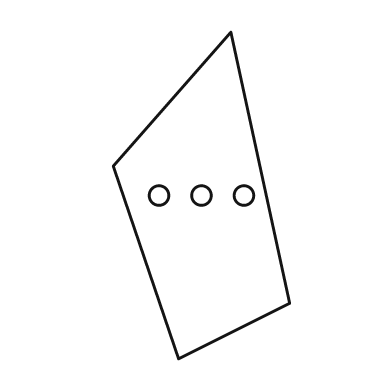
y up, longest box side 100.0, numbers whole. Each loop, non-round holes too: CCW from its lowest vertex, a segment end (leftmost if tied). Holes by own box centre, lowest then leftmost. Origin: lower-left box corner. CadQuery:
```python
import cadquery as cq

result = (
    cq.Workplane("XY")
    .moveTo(20.0, 0.0)
    .lineTo(54.0, 17.0)
    .lineTo(36.0, 100.0)
    .lineTo(0.0, 59.0)
    .close()
    .moveTo(14.0, 50.0)
    .circle(3.0)
    .moveTo(27.0, 50.0)
    .circle(3.0)
    .moveTo(40.0, 50.0)
    .circle(3.0)
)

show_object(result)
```